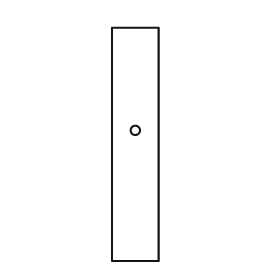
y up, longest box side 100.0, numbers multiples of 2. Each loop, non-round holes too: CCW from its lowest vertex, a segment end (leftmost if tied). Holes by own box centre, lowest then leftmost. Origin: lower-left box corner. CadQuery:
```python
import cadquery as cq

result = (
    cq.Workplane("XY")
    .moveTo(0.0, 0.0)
    .lineTo(20.0, 0.0)
    .lineTo(20.0, 100.0)
    .lineTo(0.0, 100.0)
    .close()
    .moveTo(10.0, 56.0)
    .circle(2.0)
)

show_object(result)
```